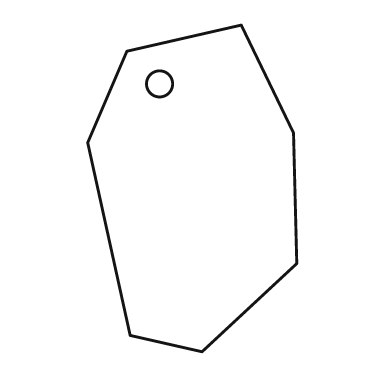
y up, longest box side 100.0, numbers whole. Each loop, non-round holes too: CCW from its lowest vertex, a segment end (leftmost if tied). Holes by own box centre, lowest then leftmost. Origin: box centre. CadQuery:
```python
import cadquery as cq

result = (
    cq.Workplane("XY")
    .moveTo(3.0, -50.0)
    .lineTo(32.0, -23.0)
    .lineTo(31.0, 17.0)
    .lineTo(15.0, 50.0)
    .lineTo(-20.0, 42.0)
    .lineTo(-32.0, 14.0)
    .lineTo(-19.0, -45.0)
    .close()
    .moveTo(-10.0, 32.0)
    .circle(4.0)
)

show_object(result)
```